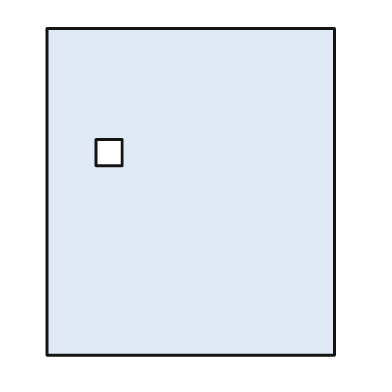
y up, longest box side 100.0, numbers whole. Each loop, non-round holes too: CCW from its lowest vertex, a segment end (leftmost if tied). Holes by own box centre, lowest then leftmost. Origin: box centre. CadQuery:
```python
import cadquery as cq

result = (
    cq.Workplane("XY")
    .moveTo(-44.0, -50.0)
    .lineTo(44.0, -50.0)
    .lineTo(44.0, 50.0)
    .lineTo(-44.0, 50.0)
    .close()
    .moveTo(-29.0, 8.0)
    .lineTo(-21.0, 8.0)
    .lineTo(-21.0, 16.0)
    .lineTo(-29.0, 16.0)
    .close()
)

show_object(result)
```